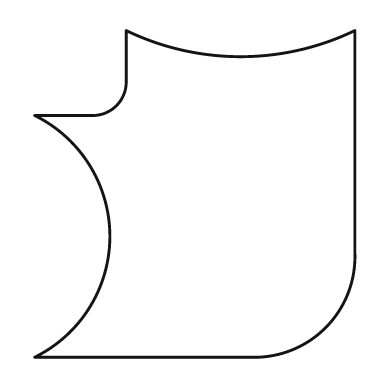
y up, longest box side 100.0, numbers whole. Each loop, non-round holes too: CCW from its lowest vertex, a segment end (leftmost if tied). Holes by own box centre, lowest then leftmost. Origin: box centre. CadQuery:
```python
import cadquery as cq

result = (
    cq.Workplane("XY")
    .moveTo(-49.0, -50.0)
    .lineTo(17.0, -50.0)
    .threePointArc((40.0, -41.0), (49.0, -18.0))
    .lineTo(49.0, 50.0)
    .threePointArc((14.0, 42.0), (-21.0, 50.0))
    .lineTo(-21.0, 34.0)
    .threePointArc((-24.0, 27.0), (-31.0, 24.0))
    .lineTo(-49.0, 24.0)
    .threePointArc((-26.0, -13.0), (-49.0, -50.0))
    .close()
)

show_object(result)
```